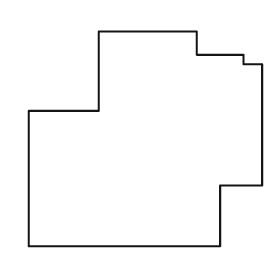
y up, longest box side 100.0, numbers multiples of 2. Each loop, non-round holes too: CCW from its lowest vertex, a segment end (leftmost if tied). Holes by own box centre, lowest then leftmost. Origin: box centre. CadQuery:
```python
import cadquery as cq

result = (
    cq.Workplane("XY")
    .moveTo(-50.0, -46.0)
    .lineTo(32.0, -46.0)
    .lineTo(32.0, -20.0)
    .lineTo(50.0, -20.0)
    .lineTo(50.0, 32.0)
    .lineTo(42.0, 32.0)
    .lineTo(42.0, 36.0)
    .lineTo(22.0, 36.0)
    .lineTo(22.0, 46.0)
    .lineTo(-20.0, 46.0)
    .lineTo(-20.0, 12.0)
    .lineTo(-50.0, 12.0)
    .close()
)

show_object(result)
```